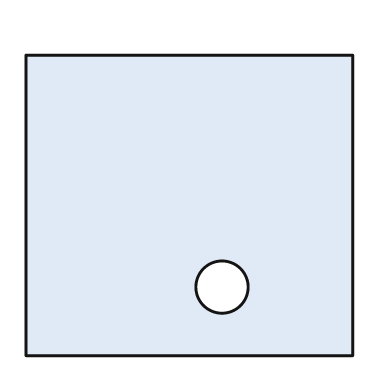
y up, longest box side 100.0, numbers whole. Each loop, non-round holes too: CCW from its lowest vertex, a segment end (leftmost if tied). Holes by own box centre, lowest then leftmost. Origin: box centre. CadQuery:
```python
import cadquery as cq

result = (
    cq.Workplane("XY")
    .moveTo(-50.0, -46.0)
    .lineTo(50.0, -46.0)
    .lineTo(50.0, 46.0)
    .lineTo(-50.0, 46.0)
    .close()
    .moveTo(10.0, -25.0)
    .circle(8.0)
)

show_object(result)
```